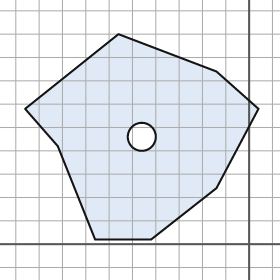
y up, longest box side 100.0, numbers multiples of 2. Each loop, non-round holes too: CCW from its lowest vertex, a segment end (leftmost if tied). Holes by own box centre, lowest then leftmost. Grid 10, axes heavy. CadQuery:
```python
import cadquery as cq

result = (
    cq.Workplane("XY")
    .moveTo(-66.0, 2.0)
    .lineTo(-42.0, 2.0)
    .lineTo(-14.0, 24.0)
    .lineTo(4.0, 58.0)
    .lineTo(-14.0, 74.0)
    .lineTo(-56.0, 90.0)
    .lineTo(-96.0, 58.0)
    .lineTo(-82.0, 42.0)
    .close()
    .moveTo(-46.0, 46.0)
    .circle(6.0)
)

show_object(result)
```